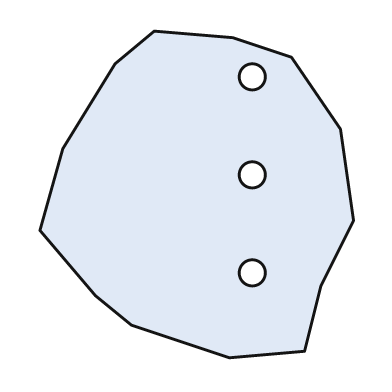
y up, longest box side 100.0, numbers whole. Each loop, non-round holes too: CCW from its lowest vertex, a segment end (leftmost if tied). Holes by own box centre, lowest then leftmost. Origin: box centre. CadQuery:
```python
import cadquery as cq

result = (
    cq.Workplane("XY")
    .moveTo(10.0, -50.0)
    .lineTo(33.0, -48.0)
    .lineTo(38.0, -28.0)
    .lineTo(48.0, -8.0)
    .lineTo(44.0, 20.0)
    .lineTo(29.0, 42.0)
    .lineTo(11.0, 48.0)
    .lineTo(-13.0, 50.0)
    .lineTo(-25.0, 40.0)
    .lineTo(-41.0, 14.0)
    .lineTo(-48.0, -11.0)
    .lineTo(-31.0, -31.0)
    .lineTo(-20.0, -40.0)
    .close()
    .moveTo(17.0, -24.0)
    .circle(4.0)
    .moveTo(17.0, 6.0)
    .circle(4.0)
    .moveTo(17.0, 36.0)
    .circle(4.0)
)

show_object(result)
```